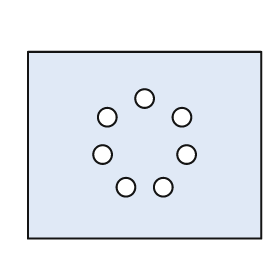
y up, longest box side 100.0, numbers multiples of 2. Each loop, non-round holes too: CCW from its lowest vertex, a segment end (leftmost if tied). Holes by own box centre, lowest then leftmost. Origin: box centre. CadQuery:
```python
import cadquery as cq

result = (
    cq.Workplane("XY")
    .moveTo(-50.0, -40.0)
    .lineTo(50.0, -40.0)
    .lineTo(50.0, 40.0)
    .lineTo(-50.0, 40.0)
    .close()
    .moveTo(-8.0, -18.0)
    .circle(4.0)
    .moveTo(8.0, -18.0)
    .circle(4.0)
    .moveTo(-18.0, -4.0)
    .circle(4.0)
    .moveTo(18.0, -4.0)
    .circle(4.0)
    .moveTo(-16.0, 12.0)
    .circle(4.0)
    .moveTo(16.0, 12.0)
    .circle(4.0)
    .moveTo(0.0, 20.0)
    .circle(4.0)
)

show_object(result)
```